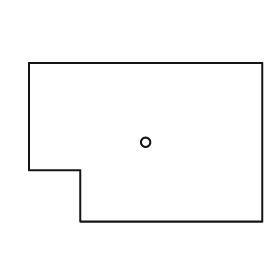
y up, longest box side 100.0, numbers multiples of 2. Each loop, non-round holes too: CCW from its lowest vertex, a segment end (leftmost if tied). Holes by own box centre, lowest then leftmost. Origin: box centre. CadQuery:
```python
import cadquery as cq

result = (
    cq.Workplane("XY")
    .moveTo(-28.0, -34.0)
    .lineTo(50.0, -34.0)
    .lineTo(50.0, 34.0)
    .lineTo(-50.0, 34.0)
    .lineTo(-50.0, -12.0)
    .lineTo(-28.0, -12.0)
    .close()
    .moveTo(0.0, 0.0)
    .circle(2.0)
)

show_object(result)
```